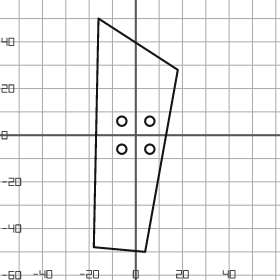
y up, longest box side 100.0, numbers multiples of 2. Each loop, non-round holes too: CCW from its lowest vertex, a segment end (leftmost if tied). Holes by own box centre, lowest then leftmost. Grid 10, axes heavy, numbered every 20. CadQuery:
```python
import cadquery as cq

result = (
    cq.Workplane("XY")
    .moveTo(4.0, -50.0)
    .lineTo(18.0, 28.0)
    .lineTo(-16.0, 50.0)
    .lineTo(-18.0, -48.0)
    .close()
    .moveTo(-6.0, -6.0)
    .circle(2.0)
    .moveTo(6.0, -6.0)
    .circle(2.0)
    .moveTo(-6.0, 6.0)
    .circle(2.0)
    .moveTo(6.0, 6.0)
    .circle(2.0)
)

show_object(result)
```